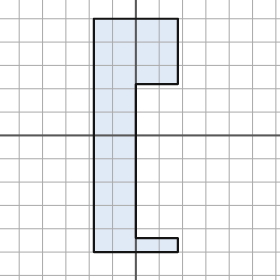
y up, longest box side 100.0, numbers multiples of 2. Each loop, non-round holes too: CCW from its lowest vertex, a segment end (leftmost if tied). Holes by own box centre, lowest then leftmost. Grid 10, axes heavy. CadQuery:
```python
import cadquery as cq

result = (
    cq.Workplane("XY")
    .moveTo(-18.0, -50.0)
    .lineTo(18.0, -50.0)
    .lineTo(18.0, -44.0)
    .lineTo(0.0, -44.0)
    .lineTo(0.0, 22.0)
    .lineTo(18.0, 22.0)
    .lineTo(18.0, 50.0)
    .lineTo(-18.0, 50.0)
    .close()
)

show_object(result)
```